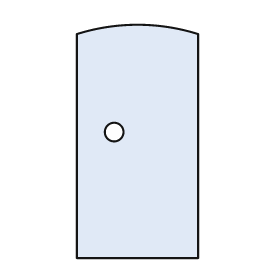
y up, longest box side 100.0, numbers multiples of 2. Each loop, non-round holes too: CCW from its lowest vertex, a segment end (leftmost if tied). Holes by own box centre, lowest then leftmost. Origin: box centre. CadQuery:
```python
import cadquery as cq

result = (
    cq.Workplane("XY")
    .moveTo(-26.0, -50.0)
    .lineTo(26.0, -50.0)
    .lineTo(26.0, 46.0)
    .threePointArc((0.0, 50.0), (-26.0, 46.0))
    .close()
    .moveTo(-10.0, 4.0)
    .circle(4.0)
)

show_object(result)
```